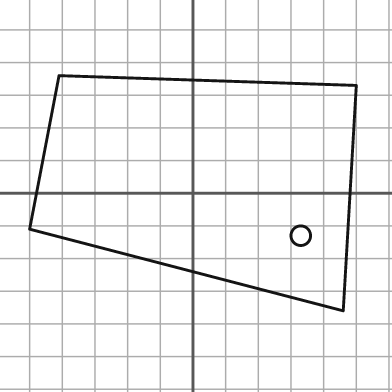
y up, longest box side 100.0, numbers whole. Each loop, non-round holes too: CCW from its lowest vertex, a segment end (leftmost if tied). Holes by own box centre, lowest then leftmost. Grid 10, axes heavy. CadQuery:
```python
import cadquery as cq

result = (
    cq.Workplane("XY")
    .moveTo(46.0, -36.0)
    .lineTo(50.0, 33.0)
    .lineTo(-41.0, 36.0)
    .lineTo(-50.0, -11.0)
    .close()
    .moveTo(33.0, -13.0)
    .circle(3.0)
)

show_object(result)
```